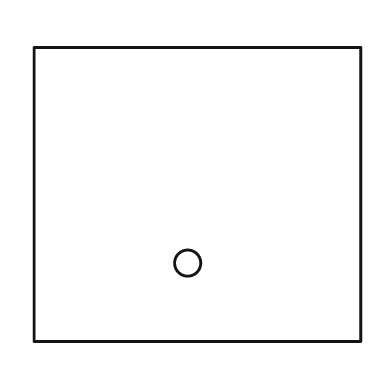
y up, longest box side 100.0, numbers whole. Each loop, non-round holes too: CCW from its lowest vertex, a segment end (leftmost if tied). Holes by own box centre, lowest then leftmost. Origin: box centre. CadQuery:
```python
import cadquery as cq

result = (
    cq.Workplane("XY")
    .moveTo(-50.0, -45.0)
    .lineTo(50.0, -45.0)
    .lineTo(50.0, 45.0)
    .lineTo(-50.0, 45.0)
    .close()
    .moveTo(-3.0, -21.0)
    .circle(4.0)
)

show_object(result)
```